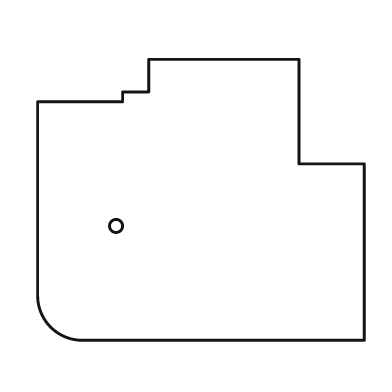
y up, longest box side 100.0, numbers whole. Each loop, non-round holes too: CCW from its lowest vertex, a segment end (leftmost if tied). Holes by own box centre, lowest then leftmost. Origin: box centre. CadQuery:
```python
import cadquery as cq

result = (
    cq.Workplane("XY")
    .moveTo(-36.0, -43.0)
    .lineTo(50.0, -43.0)
    .lineTo(50.0, 11.0)
    .lineTo(30.0, 11.0)
    .lineTo(30.0, 43.0)
    .lineTo(-16.0, 43.0)
    .lineTo(-16.0, 33.0)
    .lineTo(-24.0, 33.0)
    .lineTo(-24.0, 30.0)
    .lineTo(-50.0, 30.0)
    .lineTo(-50.0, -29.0)
    .threePointArc((-46.0, -39.0), (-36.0, -43.0))
    .close()
    .moveTo(-26.0, -8.0)
    .circle(2.0)
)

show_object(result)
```